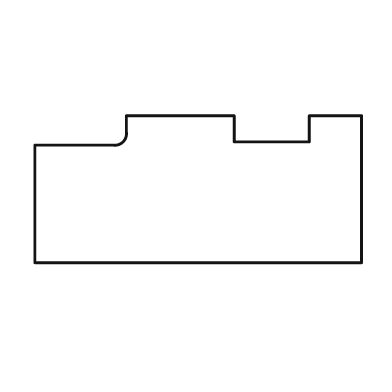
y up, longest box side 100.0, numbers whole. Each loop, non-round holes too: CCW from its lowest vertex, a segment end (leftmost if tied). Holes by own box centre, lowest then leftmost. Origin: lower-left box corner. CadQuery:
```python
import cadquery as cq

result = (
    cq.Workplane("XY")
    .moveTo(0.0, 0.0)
    .lineTo(100.0, 0.0)
    .lineTo(100.0, 45.0)
    .lineTo(84.0, 45.0)
    .lineTo(84.0, 37.0)
    .lineTo(61.0, 37.0)
    .lineTo(61.0, 45.0)
    .lineTo(28.0, 45.0)
    .lineTo(28.0, 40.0)
    .threePointArc((27.0, 37.0), (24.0, 36.0))
    .lineTo(0.0, 36.0)
    .close()
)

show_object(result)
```